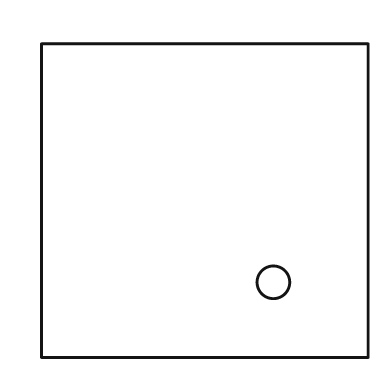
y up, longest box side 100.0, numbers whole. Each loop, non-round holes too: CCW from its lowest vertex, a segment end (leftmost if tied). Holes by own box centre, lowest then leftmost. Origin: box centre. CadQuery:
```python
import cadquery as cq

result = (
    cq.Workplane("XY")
    .moveTo(-50.0, -48.0)
    .lineTo(50.0, -48.0)
    .lineTo(50.0, 48.0)
    .lineTo(-50.0, 48.0)
    .close()
    .moveTo(21.0, -25.0)
    .circle(5.0)
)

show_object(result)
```